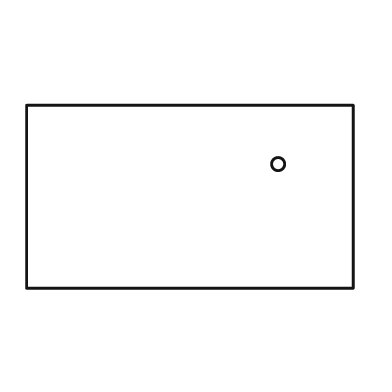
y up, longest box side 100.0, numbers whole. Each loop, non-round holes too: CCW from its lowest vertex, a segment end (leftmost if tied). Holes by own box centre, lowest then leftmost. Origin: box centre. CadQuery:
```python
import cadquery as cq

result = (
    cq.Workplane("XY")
    .moveTo(-50.0, -28.0)
    .lineTo(50.0, -28.0)
    .lineTo(50.0, 28.0)
    .lineTo(-50.0, 28.0)
    .close()
    .moveTo(27.0, 10.0)
    .circle(2.0)
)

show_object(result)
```